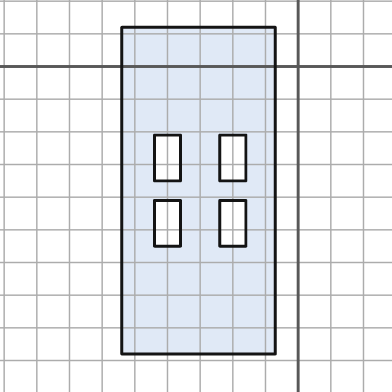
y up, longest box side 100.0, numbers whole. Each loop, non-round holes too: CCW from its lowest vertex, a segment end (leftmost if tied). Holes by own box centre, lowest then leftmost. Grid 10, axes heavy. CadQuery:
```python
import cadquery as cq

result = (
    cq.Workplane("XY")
    .moveTo(-54.0, -88.0)
    .lineTo(-7.0, -88.0)
    .lineTo(-7.0, 12.0)
    .lineTo(-54.0, 12.0)
    .close()
    .moveTo(-44.0, -55.0)
    .lineTo(-36.0, -55.0)
    .lineTo(-36.0, -41.0)
    .lineTo(-44.0, -41.0)
    .close()
    .moveTo(-24.0, -55.0)
    .lineTo(-16.0, -55.0)
    .lineTo(-16.0, -41.0)
    .lineTo(-24.0, -41.0)
    .close()
    .moveTo(-44.0, -35.0)
    .lineTo(-36.0, -35.0)
    .lineTo(-36.0, -21.0)
    .lineTo(-44.0, -21.0)
    .close()
    .moveTo(-24.0, -35.0)
    .lineTo(-16.0, -35.0)
    .lineTo(-16.0, -21.0)
    .lineTo(-24.0, -21.0)
    .close()
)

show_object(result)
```